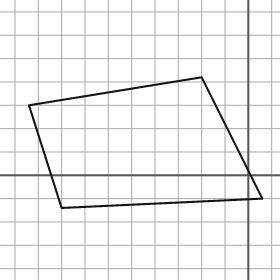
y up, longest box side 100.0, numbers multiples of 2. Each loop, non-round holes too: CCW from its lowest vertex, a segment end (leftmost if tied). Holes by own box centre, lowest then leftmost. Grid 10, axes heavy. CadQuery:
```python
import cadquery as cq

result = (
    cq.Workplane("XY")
    .moveTo(-80.0, -14.0)
    .lineTo(6.0, -10.0)
    .lineTo(-20.0, 42.0)
    .lineTo(-94.0, 30.0)
    .close()
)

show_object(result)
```